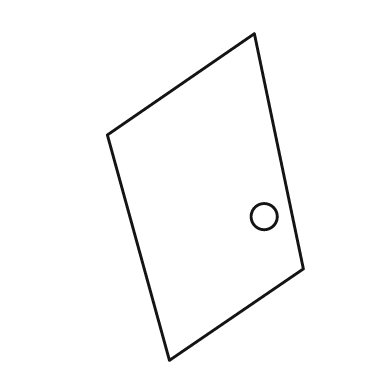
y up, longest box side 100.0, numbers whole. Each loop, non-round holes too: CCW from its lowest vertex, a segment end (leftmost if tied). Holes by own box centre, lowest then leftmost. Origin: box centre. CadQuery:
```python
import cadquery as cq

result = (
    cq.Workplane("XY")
    .moveTo(-11.0, -50.0)
    .lineTo(30.0, -22.0)
    .lineTo(15.0, 50.0)
    .lineTo(-30.0, 19.0)
    .close()
    .moveTo(18.0, -6.0)
    .circle(4.0)
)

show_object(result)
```